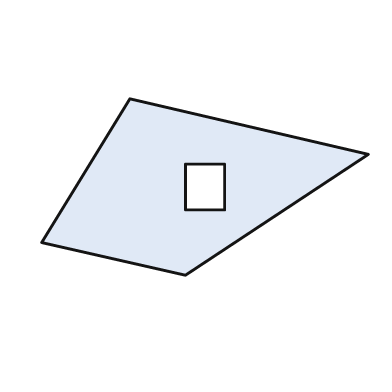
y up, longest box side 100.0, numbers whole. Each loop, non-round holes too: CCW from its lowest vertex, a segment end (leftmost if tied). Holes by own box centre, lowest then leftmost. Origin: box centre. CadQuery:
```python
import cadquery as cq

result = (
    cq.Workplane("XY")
    .moveTo(-6.0, -27.0)
    .lineTo(50.0, 10.0)
    .lineTo(-23.0, 27.0)
    .lineTo(-50.0, -17.0)
    .close()
    .moveTo(-6.0, -7.0)
    .lineTo(6.0, -7.0)
    .lineTo(6.0, 7.0)
    .lineTo(-6.0, 7.0)
    .close()
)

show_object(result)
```